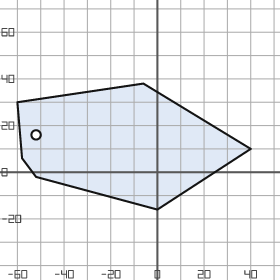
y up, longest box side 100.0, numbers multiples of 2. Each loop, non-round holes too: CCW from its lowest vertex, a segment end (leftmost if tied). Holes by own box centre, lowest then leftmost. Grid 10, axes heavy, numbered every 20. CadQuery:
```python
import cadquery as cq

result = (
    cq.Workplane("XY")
    .moveTo(0.0, -16.0)
    .lineTo(40.0, 10.0)
    .lineTo(-6.0, 38.0)
    .lineTo(-60.0, 30.0)
    .lineTo(-58.0, 6.0)
    .lineTo(-52.0, -2.0)
    .close()
    .moveTo(-52.0, 16.0)
    .circle(2.0)
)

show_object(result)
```